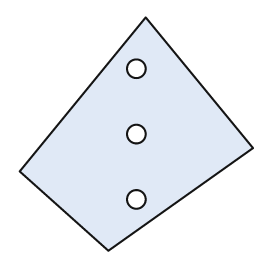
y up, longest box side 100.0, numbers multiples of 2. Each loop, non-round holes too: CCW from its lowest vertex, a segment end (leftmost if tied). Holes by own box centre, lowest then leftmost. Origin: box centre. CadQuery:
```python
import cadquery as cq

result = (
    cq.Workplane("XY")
    .moveTo(-12.0, -50.0)
    .lineTo(50.0, -6.0)
    .lineTo(4.0, 50.0)
    .lineTo(-50.0, -16.0)
    .close()
    .moveTo(0.0, -28.0)
    .circle(4.0)
    .moveTo(0.0, 0.0)
    .circle(4.0)
    .moveTo(0.0, 28.0)
    .circle(4.0)
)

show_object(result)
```